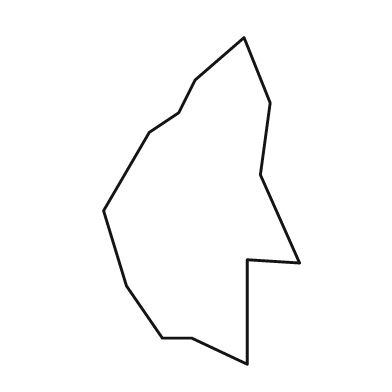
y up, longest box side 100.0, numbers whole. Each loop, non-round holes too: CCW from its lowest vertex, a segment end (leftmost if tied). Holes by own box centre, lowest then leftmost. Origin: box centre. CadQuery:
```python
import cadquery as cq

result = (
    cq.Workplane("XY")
    .moveTo(14.0, -50.0)
    .lineTo(14.0, -18.0)
    .lineTo(30.0, -19.0)
    .lineTo(18.0, 8.0)
    .lineTo(21.0, 30.0)
    .lineTo(13.0, 50.0)
    .lineTo(-2.0, 37.0)
    .lineTo(-7.0, 27.0)
    .lineTo(-16.0, 21.0)
    .lineTo(-30.0, -3.0)
    .lineTo(-23.0, -26.0)
    .lineTo(-12.0, -42.0)
    .lineTo(-3.0, -42.0)
    .close()
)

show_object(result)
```